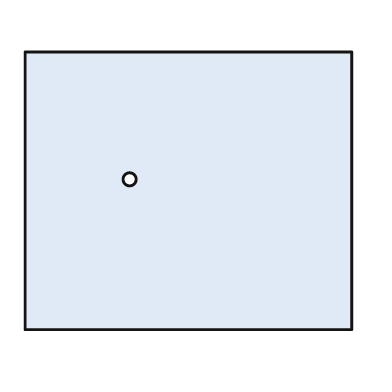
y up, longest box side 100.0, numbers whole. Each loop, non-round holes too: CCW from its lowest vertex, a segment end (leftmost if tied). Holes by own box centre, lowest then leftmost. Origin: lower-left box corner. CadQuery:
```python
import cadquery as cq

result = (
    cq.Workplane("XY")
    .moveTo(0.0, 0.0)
    .lineTo(100.0, 0.0)
    .lineTo(100.0, 85.0)
    .lineTo(0.0, 85.0)
    .close()
    .moveTo(32.0, 46.0)
    .circle(2.0)
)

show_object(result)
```